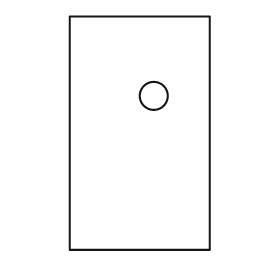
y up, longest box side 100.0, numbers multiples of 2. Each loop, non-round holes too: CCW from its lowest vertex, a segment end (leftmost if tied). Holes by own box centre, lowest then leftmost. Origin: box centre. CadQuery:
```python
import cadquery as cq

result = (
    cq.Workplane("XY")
    .moveTo(-30.0, -50.0)
    .lineTo(30.0, -50.0)
    .lineTo(30.0, 50.0)
    .lineTo(-30.0, 50.0)
    .close()
    .moveTo(6.0, 16.0)
    .circle(6.0)
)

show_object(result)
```